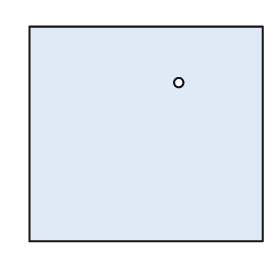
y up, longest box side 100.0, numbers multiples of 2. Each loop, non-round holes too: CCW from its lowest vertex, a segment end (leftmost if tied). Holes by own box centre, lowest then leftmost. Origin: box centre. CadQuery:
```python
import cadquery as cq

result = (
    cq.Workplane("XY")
    .moveTo(-50.0, -46.0)
    .lineTo(50.0, -46.0)
    .lineTo(50.0, 46.0)
    .lineTo(-50.0, 46.0)
    .close()
    .moveTo(14.0, 22.0)
    .circle(2.0)
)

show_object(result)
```